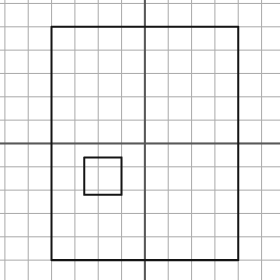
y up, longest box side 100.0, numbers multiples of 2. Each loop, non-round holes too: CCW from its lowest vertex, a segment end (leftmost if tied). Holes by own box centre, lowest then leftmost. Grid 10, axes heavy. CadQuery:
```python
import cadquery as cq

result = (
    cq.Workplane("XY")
    .moveTo(-40.0, -50.0)
    .lineTo(40.0, -50.0)
    .lineTo(40.0, 50.0)
    .lineTo(-40.0, 50.0)
    .close()
    .moveTo(-26.0, -22.0)
    .lineTo(-10.0, -22.0)
    .lineTo(-10.0, -6.0)
    .lineTo(-26.0, -6.0)
    .close()
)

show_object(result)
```